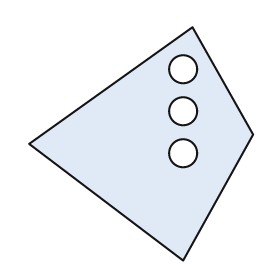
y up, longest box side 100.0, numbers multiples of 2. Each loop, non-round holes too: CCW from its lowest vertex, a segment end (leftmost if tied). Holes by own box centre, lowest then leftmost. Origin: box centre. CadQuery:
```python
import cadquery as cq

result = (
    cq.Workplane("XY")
    .moveTo(18.0, -50.0)
    .lineTo(48.0, 4.0)
    .lineTo(22.0, 50.0)
    .lineTo(-48.0, 0.0)
    .close()
    .moveTo(18.0, -4.0)
    .circle(6.0)
    .moveTo(18.0, 14.0)
    .circle(6.0)
    .moveTo(18.0, 32.0)
    .circle(6.0)
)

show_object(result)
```